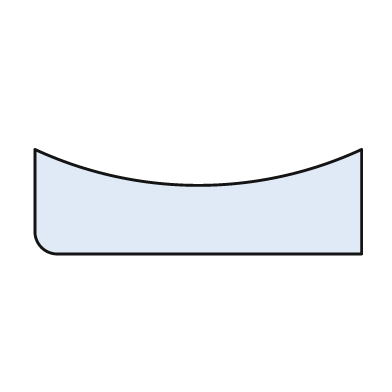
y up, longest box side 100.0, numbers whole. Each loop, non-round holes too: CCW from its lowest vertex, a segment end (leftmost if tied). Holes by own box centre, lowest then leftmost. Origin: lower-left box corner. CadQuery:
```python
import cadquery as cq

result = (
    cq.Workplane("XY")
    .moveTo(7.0, 0.0)
    .lineTo(100.0, 0.0)
    .lineTo(100.0, 32.0)
    .threePointArc((50.0, 21.0), (0.0, 32.0))
    .lineTo(0.0, 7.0)
    .threePointArc((2.0, 2.0), (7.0, 0.0))
    .close()
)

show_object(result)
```